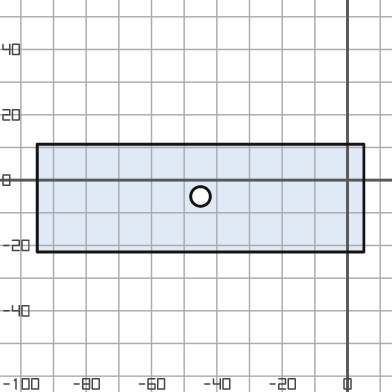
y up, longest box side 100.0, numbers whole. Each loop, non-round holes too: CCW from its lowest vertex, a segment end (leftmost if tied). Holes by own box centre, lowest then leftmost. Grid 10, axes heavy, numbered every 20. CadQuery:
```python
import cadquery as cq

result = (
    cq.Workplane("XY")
    .moveTo(-95.0, -22.0)
    .lineTo(5.0, -22.0)
    .lineTo(5.0, 11.0)
    .lineTo(-95.0, 11.0)
    .close()
    .moveTo(-45.0, -5.0)
    .circle(3.0)
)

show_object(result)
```